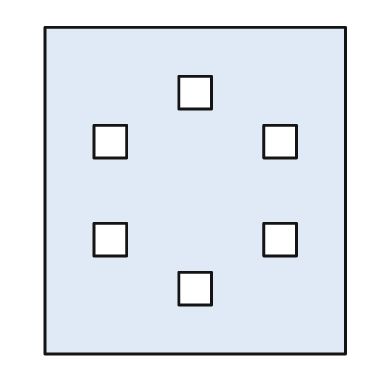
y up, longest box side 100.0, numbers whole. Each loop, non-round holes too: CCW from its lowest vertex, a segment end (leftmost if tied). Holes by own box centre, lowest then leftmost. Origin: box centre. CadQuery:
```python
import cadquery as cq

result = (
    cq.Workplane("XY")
    .moveTo(-46.0, -50.0)
    .lineTo(46.0, -50.0)
    .lineTo(46.0, 50.0)
    .lineTo(-46.0, 50.0)
    .close()
    .moveTo(-5.0, -35.0)
    .lineTo(5.0, -35.0)
    .lineTo(5.0, -25.0)
    .lineTo(-5.0, -25.0)
    .close()
    .moveTo(-31.0, -20.0)
    .lineTo(-21.0, -20.0)
    .lineTo(-21.0, -10.0)
    .lineTo(-31.0, -10.0)
    .close()
    .moveTo(21.0, -20.0)
    .lineTo(31.0, -20.0)
    .lineTo(31.0, -10.0)
    .lineTo(21.0, -10.0)
    .close()
    .moveTo(-31.0, 10.0)
    .lineTo(-21.0, 10.0)
    .lineTo(-21.0, 20.0)
    .lineTo(-31.0, 20.0)
    .close()
    .moveTo(21.0, 10.0)
    .lineTo(31.0, 10.0)
    .lineTo(31.0, 20.0)
    .lineTo(21.0, 20.0)
    .close()
    .moveTo(-5.0, 25.0)
    .lineTo(5.0, 25.0)
    .lineTo(5.0, 35.0)
    .lineTo(-5.0, 35.0)
    .close()
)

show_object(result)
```